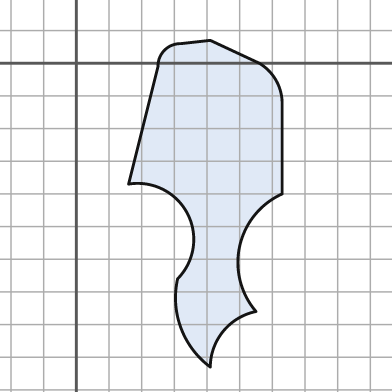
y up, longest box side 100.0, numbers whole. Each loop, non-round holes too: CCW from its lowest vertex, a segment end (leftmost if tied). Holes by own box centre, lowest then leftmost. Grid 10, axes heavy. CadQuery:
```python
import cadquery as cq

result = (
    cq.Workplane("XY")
    .moveTo(41.0, -93.0)
    .threePointArc((45.0, -82.0), (55.0, -76.0))
    .threePointArc((50.0, -56.0), (63.0, -40.0))
    .lineTo(63.0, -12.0)
    .threePointArc((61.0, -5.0), (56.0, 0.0))
    .lineTo(41.0, 7.0)
    .lineTo(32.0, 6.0)
    .threePointArc((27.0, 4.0), (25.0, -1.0))
    .lineTo(16.0, -37.0)
    .threePointArc((34.0, -46.0), (31.0, -66.0))
    .threePointArc((32.0, -81.0), (41.0, -93.0))
    .close()
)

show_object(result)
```